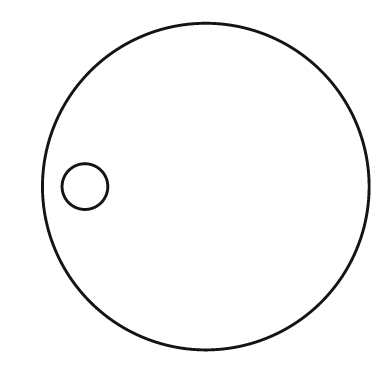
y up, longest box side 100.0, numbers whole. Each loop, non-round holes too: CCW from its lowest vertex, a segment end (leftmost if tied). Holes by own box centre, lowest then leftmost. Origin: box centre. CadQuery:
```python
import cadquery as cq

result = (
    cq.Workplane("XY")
    .moveTo(0.0, 0.0)
    .circle(50.0)
    .moveTo(-37.0, 0.0)
    .circle(7.0)
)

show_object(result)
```